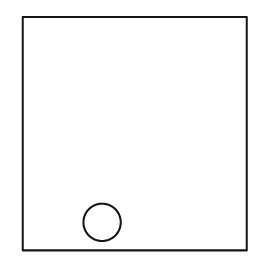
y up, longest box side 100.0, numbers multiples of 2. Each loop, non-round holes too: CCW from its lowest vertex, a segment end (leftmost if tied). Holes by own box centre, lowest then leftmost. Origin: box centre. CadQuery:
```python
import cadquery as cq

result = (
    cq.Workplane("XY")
    .moveTo(-48.0, -50.0)
    .lineTo(48.0, -50.0)
    .lineTo(48.0, 50.0)
    .lineTo(-48.0, 50.0)
    .close()
    .moveTo(-14.0, -38.0)
    .circle(8.0)
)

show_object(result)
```